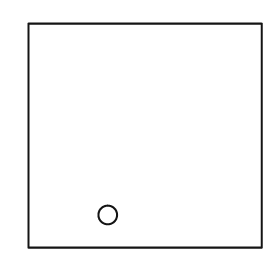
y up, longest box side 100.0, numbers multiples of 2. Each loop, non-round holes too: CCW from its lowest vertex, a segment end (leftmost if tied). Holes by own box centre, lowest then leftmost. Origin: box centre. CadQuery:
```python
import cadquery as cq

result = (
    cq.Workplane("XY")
    .moveTo(-50.0, -48.0)
    .lineTo(50.0, -48.0)
    .lineTo(50.0, 48.0)
    .lineTo(-50.0, 48.0)
    .close()
    .moveTo(-16.0, -34.0)
    .circle(4.0)
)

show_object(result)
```